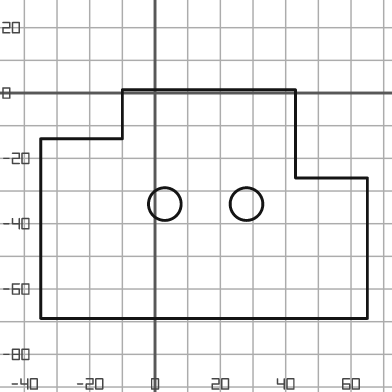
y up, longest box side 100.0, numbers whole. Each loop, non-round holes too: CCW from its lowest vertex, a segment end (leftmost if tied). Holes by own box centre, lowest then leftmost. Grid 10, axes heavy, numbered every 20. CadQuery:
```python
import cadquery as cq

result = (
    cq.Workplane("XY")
    .moveTo(-35.0, -69.0)
    .lineTo(65.0, -69.0)
    .lineTo(65.0, -26.0)
    .lineTo(43.0, -26.0)
    .lineTo(43.0, 1.0)
    .lineTo(-10.0, 1.0)
    .lineTo(-10.0, -14.0)
    .lineTo(-35.0, -14.0)
    .close()
    .moveTo(3.0, -34.0)
    .circle(5.0)
    .moveTo(28.0, -34.0)
    .circle(5.0)
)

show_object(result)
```